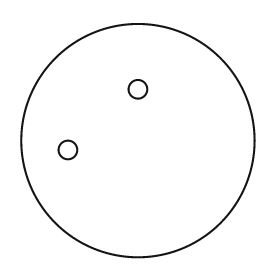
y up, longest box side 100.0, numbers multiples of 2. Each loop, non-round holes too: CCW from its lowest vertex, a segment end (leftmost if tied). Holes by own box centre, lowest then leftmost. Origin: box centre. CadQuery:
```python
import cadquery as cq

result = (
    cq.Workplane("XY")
    .moveTo(0.0, 0.0)
    .circle(50.0)
    .moveTo(-30.0, -4.0)
    .circle(4.0)
    .moveTo(0.0, 22.0)
    .circle(4.0)
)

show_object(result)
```